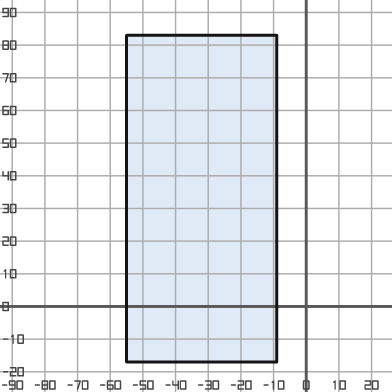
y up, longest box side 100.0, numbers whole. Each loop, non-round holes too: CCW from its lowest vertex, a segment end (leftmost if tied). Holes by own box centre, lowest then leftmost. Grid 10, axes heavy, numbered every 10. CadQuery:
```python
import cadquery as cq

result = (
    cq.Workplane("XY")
    .moveTo(-55.0, -17.0)
    .lineTo(-9.0, -17.0)
    .lineTo(-9.0, 83.0)
    .lineTo(-55.0, 83.0)
    .close()
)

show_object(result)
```